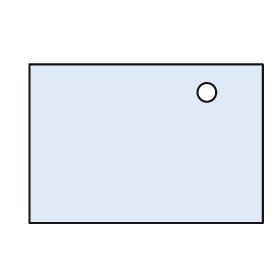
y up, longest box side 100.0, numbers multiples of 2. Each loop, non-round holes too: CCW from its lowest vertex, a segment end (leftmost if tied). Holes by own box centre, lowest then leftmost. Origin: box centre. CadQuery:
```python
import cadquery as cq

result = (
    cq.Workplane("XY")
    .moveTo(-50.0, -34.0)
    .lineTo(50.0, -34.0)
    .lineTo(50.0, 34.0)
    .lineTo(-50.0, 34.0)
    .close()
    .moveTo(26.0, 22.0)
    .circle(4.0)
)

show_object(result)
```